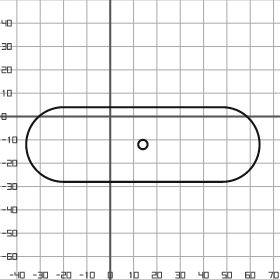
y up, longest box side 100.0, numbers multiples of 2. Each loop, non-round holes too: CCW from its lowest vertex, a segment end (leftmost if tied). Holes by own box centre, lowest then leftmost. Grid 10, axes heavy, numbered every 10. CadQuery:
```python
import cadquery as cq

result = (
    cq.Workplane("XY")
    .moveTo(-20.0, -28.0)
    .lineTo(48.0, -28.0)
    .threePointArc((64.0, -12.0), (48.0, 4.0))
    .lineTo(-20.0, 4.0)
    .threePointArc((-36.0, -12.0), (-20.0, -28.0))
    .close()
    .moveTo(14.0, -12.0)
    .circle(2.0)
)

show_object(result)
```